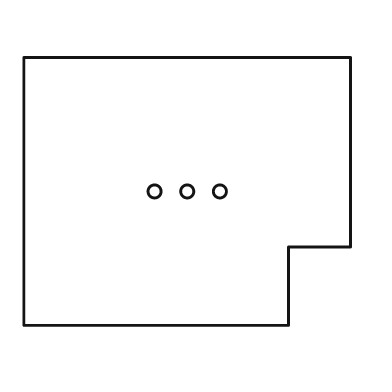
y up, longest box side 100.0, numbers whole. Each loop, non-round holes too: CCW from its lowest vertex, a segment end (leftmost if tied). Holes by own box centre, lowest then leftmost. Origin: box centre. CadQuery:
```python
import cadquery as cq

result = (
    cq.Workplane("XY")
    .moveTo(-50.0, -41.0)
    .lineTo(31.0, -41.0)
    .lineTo(31.0, -17.0)
    .lineTo(50.0, -17.0)
    .lineTo(50.0, 41.0)
    .lineTo(-50.0, 41.0)
    .close()
    .moveTo(-10.0, 0.0)
    .circle(2.0)
    .moveTo(0.0, 0.0)
    .circle(2.0)
    .moveTo(10.0, 0.0)
    .circle(2.0)
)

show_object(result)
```